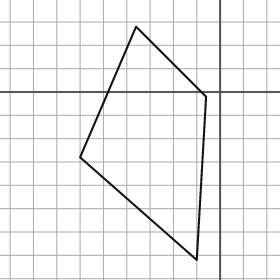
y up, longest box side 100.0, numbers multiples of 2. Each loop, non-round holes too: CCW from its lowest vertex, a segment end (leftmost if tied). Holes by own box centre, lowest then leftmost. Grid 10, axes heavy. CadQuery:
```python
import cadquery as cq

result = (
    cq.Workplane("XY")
    .moveTo(-10.0, -72.0)
    .lineTo(-6.0, -2.0)
    .lineTo(-36.0, 28.0)
    .lineTo(-60.0, -28.0)
    .close()
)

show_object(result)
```